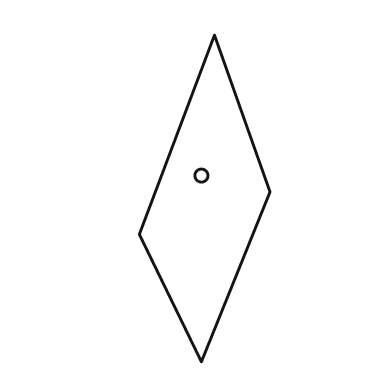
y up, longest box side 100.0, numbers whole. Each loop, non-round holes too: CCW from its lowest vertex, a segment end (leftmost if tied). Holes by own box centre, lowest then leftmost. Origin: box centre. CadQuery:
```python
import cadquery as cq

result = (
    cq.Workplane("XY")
    .moveTo(-1.0, -50.0)
    .lineTo(20.0, 2.0)
    .lineTo(3.0, 50.0)
    .lineTo(-20.0, -11.0)
    .close()
    .moveTo(-1.0, 7.0)
    .circle(2.0)
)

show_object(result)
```